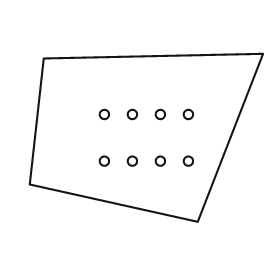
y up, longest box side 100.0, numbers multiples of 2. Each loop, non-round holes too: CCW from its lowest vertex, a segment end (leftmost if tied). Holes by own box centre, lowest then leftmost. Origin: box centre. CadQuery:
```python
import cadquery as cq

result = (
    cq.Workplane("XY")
    .moveTo(22.0, -36.0)
    .lineTo(50.0, 36.0)
    .lineTo(-44.0, 34.0)
    .lineTo(-50.0, -20.0)
    .close()
    .moveTo(-18.0, -10.0)
    .circle(2.0)
    .moveTo(-6.0, -10.0)
    .circle(2.0)
    .moveTo(6.0, -10.0)
    .circle(2.0)
    .moveTo(18.0, -10.0)
    .circle(2.0)
    .moveTo(-18.0, 10.0)
    .circle(2.0)
    .moveTo(-6.0, 10.0)
    .circle(2.0)
    .moveTo(6.0, 10.0)
    .circle(2.0)
    .moveTo(18.0, 10.0)
    .circle(2.0)
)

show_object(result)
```